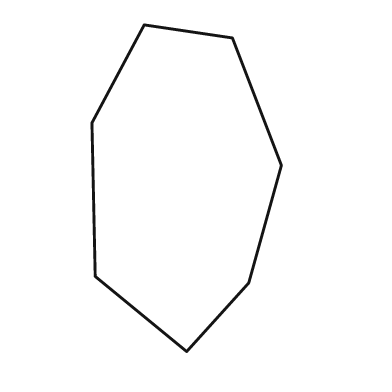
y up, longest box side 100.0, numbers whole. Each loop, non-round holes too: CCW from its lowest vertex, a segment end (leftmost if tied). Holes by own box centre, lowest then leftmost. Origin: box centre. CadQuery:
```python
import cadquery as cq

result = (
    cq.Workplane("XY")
    .moveTo(0.0, -50.0)
    .lineTo(19.0, -29.0)
    .lineTo(29.0, 7.0)
    .lineTo(14.0, 46.0)
    .lineTo(-13.0, 50.0)
    .lineTo(-29.0, 20.0)
    .lineTo(-28.0, -27.0)
    .close()
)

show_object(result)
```